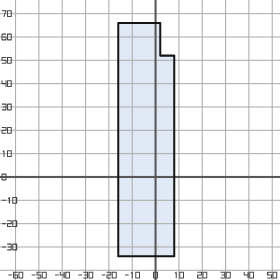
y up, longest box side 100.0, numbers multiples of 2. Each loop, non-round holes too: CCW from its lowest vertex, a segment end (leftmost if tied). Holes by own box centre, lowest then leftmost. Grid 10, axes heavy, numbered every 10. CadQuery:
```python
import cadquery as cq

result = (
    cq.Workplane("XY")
    .moveTo(-16.0, -34.0)
    .lineTo(8.0, -34.0)
    .lineTo(8.0, 52.0)
    .lineTo(2.0, 52.0)
    .lineTo(2.0, 66.0)
    .lineTo(-16.0, 66.0)
    .close()
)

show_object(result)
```